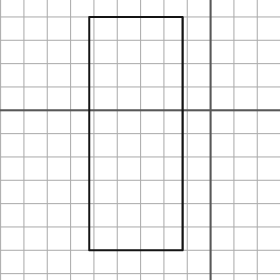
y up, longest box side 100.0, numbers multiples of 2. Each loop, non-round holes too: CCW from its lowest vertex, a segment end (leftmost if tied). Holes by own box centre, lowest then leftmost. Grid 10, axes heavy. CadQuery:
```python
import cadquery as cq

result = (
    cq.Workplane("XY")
    .moveTo(-52.0, -60.0)
    .lineTo(-12.0, -60.0)
    .lineTo(-12.0, 40.0)
    .lineTo(-52.0, 40.0)
    .close()
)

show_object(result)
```